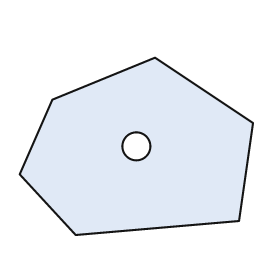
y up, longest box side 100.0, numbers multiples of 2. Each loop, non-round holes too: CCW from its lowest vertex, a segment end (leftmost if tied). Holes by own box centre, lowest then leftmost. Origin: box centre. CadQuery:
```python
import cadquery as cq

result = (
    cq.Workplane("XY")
    .moveTo(-26.0, -38.0)
    .lineTo(44.0, -32.0)
    .lineTo(50.0, 10.0)
    .lineTo(8.0, 38.0)
    .lineTo(-36.0, 20.0)
    .lineTo(-50.0, -12.0)
    .close()
    .moveTo(0.0, 0.0)
    .circle(6.0)
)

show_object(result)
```